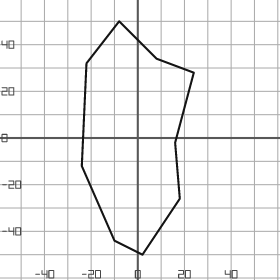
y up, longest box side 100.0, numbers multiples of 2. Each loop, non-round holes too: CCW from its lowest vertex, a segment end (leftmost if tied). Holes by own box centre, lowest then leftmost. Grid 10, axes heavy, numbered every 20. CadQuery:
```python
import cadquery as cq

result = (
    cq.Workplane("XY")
    .moveTo(2.0, -50.0)
    .lineTo(18.0, -26.0)
    .lineTo(16.0, -2.0)
    .lineTo(24.0, 28.0)
    .lineTo(8.0, 34.0)
    .lineTo(-8.0, 50.0)
    .lineTo(-22.0, 32.0)
    .lineTo(-24.0, -12.0)
    .lineTo(-10.0, -44.0)
    .close()
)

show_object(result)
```